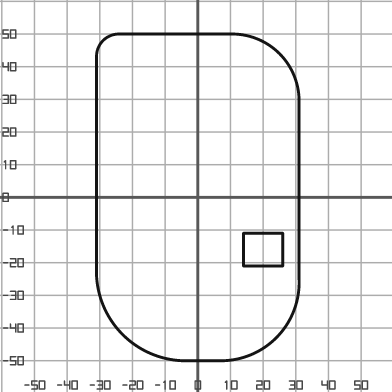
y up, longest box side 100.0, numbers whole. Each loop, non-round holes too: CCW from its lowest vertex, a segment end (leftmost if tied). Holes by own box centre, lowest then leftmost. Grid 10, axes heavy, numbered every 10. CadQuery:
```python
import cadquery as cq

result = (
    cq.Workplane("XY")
    .moveTo(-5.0, -50.0)
    .lineTo(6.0, -50.0)
    .threePointArc((24.0, -43.0), (31.0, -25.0))
    .lineTo(31.0, 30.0)
    .threePointArc((25.0, 44.0), (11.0, 50.0))
    .lineTo(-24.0, 50.0)
    .threePointArc((-29.0, 48.0), (-31.0, 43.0))
    .lineTo(-31.0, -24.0)
    .threePointArc((-23.0, -42.0), (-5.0, -50.0))
    .close()
    .moveTo(14.0, -21.0)
    .lineTo(26.0, -21.0)
    .lineTo(26.0, -11.0)
    .lineTo(14.0, -11.0)
    .close()
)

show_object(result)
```